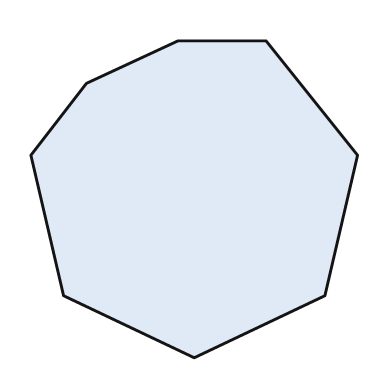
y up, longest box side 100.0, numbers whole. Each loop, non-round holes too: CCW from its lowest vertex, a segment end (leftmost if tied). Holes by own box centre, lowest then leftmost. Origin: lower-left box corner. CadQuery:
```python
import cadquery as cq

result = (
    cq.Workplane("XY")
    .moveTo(50.0, 0.0)
    .lineTo(90.0, 19.0)
    .lineTo(100.0, 62.0)
    .lineTo(72.0, 97.0)
    .lineTo(45.0, 97.0)
    .lineTo(17.0, 84.0)
    .lineTo(0.0, 62.0)
    .lineTo(10.0, 19.0)
    .close()
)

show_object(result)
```